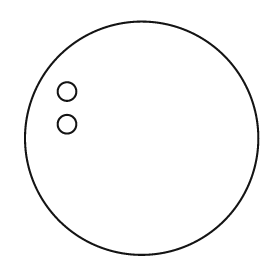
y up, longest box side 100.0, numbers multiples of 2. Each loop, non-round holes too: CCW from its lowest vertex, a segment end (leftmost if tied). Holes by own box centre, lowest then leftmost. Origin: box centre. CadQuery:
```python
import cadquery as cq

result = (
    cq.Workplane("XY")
    .moveTo(0.0, 0.0)
    .circle(50.0)
    .moveTo(-32.0, 6.0)
    .circle(4.0)
    .moveTo(-32.0, 20.0)
    .circle(4.0)
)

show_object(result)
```